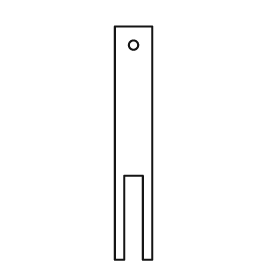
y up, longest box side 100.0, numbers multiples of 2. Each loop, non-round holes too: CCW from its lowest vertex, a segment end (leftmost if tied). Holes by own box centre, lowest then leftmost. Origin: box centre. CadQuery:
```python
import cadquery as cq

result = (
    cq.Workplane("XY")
    .moveTo(-8.0, -50.0)
    .lineTo(-4.0, -50.0)
    .lineTo(-4.0, -14.0)
    .lineTo(4.0, -14.0)
    .lineTo(4.0, -50.0)
    .lineTo(8.0, -50.0)
    .lineTo(8.0, 50.0)
    .lineTo(-8.0, 50.0)
    .close()
    .moveTo(0.0, 42.0)
    .circle(2.0)
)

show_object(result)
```